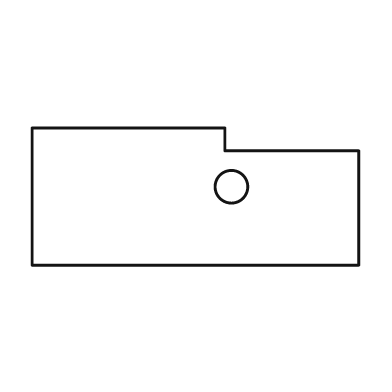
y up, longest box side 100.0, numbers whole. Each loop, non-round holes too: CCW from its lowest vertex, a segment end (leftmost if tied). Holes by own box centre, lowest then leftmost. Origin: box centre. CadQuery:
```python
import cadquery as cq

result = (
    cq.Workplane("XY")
    .moveTo(-50.0, -21.0)
    .lineTo(50.0, -21.0)
    .lineTo(50.0, 14.0)
    .lineTo(9.0, 14.0)
    .lineTo(9.0, 21.0)
    .lineTo(-50.0, 21.0)
    .close()
    .moveTo(11.0, 3.0)
    .circle(5.0)
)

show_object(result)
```